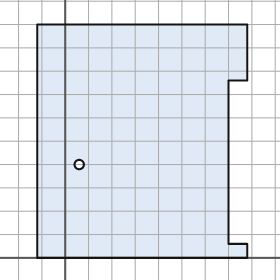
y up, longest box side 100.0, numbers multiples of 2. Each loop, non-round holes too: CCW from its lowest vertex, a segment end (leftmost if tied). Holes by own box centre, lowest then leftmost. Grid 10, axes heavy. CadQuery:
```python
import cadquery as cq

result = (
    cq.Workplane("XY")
    .moveTo(-12.0, 0.0)
    .lineTo(78.0, 0.0)
    .lineTo(78.0, 6.0)
    .lineTo(70.0, 6.0)
    .lineTo(70.0, 76.0)
    .lineTo(78.0, 76.0)
    .lineTo(78.0, 100.0)
    .lineTo(-12.0, 100.0)
    .close()
    .moveTo(6.0, 40.0)
    .circle(2.0)
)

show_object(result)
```